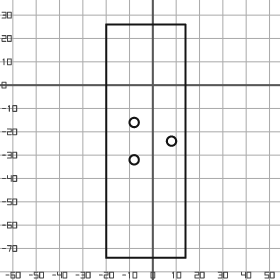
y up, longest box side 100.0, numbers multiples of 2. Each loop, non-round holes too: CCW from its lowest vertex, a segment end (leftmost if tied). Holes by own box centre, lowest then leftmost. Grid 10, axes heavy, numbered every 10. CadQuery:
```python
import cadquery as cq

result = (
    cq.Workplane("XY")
    .moveTo(-20.0, -74.0)
    .lineTo(14.0, -74.0)
    .lineTo(14.0, 26.0)
    .lineTo(-20.0, 26.0)
    .close()
    .moveTo(-8.0, -32.0)
    .circle(2.0)
    .moveTo(8.0, -24.0)
    .circle(2.0)
    .moveTo(-8.0, -16.0)
    .circle(2.0)
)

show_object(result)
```